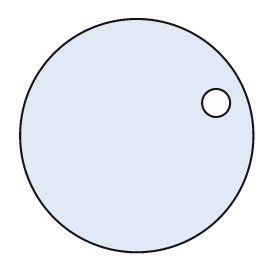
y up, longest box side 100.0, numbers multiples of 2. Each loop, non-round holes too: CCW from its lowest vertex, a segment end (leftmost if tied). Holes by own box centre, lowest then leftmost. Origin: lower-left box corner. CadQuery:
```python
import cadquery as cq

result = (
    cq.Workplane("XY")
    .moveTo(50.0, 50.0)
    .circle(50.0)
    .moveTo(84.0, 64.0)
    .circle(6.0)
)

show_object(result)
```